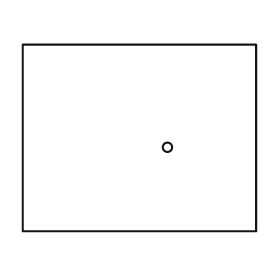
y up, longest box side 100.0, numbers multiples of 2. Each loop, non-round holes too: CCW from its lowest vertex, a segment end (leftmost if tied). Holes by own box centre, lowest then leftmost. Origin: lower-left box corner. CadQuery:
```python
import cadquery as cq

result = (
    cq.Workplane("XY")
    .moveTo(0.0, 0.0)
    .lineTo(100.0, 0.0)
    .lineTo(100.0, 80.0)
    .lineTo(0.0, 80.0)
    .close()
    .moveTo(62.0, 36.0)
    .circle(2.0)
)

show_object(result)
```